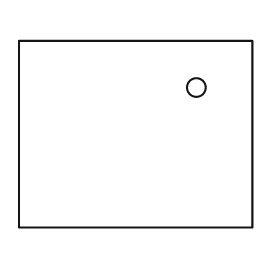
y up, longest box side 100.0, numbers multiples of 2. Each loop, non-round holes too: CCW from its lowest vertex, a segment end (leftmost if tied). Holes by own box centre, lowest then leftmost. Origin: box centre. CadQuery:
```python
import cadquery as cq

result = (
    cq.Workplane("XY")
    .moveTo(-50.0, -40.0)
    .lineTo(50.0, -40.0)
    .lineTo(50.0, 40.0)
    .lineTo(-50.0, 40.0)
    .close()
    .moveTo(26.0, 20.0)
    .circle(4.0)
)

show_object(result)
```